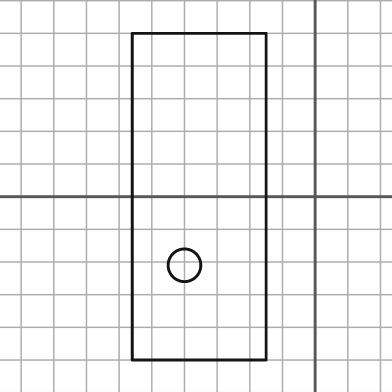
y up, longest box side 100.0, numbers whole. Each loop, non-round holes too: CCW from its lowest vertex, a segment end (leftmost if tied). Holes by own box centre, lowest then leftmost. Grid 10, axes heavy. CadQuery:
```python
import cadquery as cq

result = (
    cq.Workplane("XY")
    .moveTo(-56.0, -50.0)
    .lineTo(-15.0, -50.0)
    .lineTo(-15.0, 50.0)
    .lineTo(-56.0, 50.0)
    .close()
    .moveTo(-40.0, -21.0)
    .circle(5.0)
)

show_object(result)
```